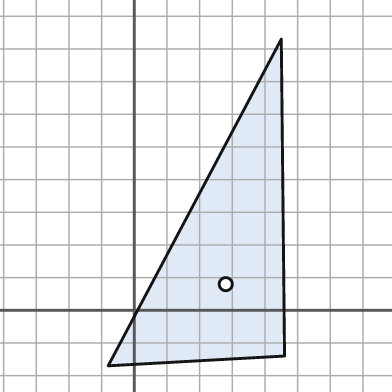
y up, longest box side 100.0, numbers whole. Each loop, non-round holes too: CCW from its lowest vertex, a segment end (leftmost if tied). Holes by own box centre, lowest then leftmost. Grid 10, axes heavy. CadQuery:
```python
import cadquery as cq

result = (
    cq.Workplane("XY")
    .moveTo(-8.0, -17.0)
    .lineTo(46.0, -14.0)
    .lineTo(45.0, 83.0)
    .close()
    .moveTo(28.0, 8.0)
    .circle(2.0)
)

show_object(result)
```